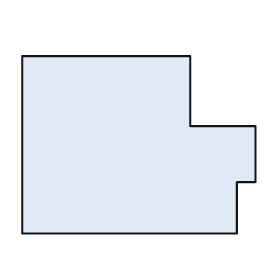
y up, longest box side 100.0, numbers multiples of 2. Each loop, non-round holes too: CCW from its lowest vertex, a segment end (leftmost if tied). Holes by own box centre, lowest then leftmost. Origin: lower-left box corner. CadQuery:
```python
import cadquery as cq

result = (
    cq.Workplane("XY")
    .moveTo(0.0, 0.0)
    .lineTo(92.0, 0.0)
    .lineTo(92.0, 22.0)
    .lineTo(100.0, 22.0)
    .lineTo(100.0, 46.0)
    .lineTo(72.0, 46.0)
    .lineTo(72.0, 76.0)
    .lineTo(0.0, 76.0)
    .close()
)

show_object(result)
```